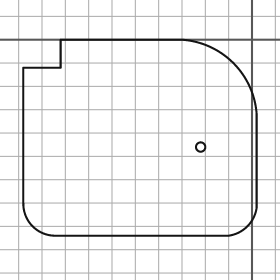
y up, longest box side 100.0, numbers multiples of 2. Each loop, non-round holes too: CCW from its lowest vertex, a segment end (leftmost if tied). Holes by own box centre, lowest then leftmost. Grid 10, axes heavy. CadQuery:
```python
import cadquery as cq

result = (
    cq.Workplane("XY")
    .moveTo(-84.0, -84.0)
    .lineTo(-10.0, -84.0)
    .threePointArc((-2.0, -80.0), (2.0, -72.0))
    .lineTo(2.0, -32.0)
    .threePointArc((-8.0, -10.0), (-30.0, 0.0))
    .lineTo(-82.0, 0.0)
    .lineTo(-82.0, -12.0)
    .lineTo(-98.0, -12.0)
    .lineTo(-98.0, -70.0)
    .threePointArc((-94.0, -80.0), (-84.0, -84.0))
    .close()
    .moveTo(-22.0, -46.0)
    .circle(2.0)
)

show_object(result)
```